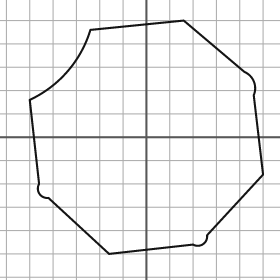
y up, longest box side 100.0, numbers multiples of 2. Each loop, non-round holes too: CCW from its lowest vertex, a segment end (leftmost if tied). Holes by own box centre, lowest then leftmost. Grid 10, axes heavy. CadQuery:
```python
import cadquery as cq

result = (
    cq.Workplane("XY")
    .moveTo(-16.0, -50.0)
    .lineTo(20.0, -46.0)
    .threePointArc((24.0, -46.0), (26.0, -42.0))
    .lineTo(50.0, -16.0)
    .lineTo(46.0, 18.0)
    .threePointArc((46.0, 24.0), (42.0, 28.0))
    .lineTo(16.0, 50.0)
    .lineTo(-24.0, 46.0)
    .threePointArc((-34.0, 28.0), (-50.0, 16.0))
    .lineTo(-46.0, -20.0)
    .threePointArc((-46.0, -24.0), (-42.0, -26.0))
    .close()
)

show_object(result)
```